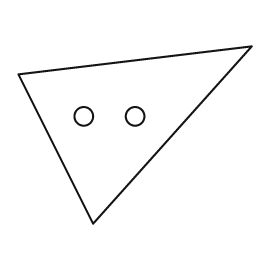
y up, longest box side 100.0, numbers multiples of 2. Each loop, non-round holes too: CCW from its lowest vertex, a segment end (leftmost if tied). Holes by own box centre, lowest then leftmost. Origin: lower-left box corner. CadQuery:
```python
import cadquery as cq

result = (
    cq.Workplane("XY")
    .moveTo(32.0, 0.0)
    .lineTo(100.0, 76.0)
    .lineTo(0.0, 64.0)
    .close()
    .moveTo(28.0, 46.0)
    .circle(4.0)
    .moveTo(50.0, 46.0)
    .circle(4.0)
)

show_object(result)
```